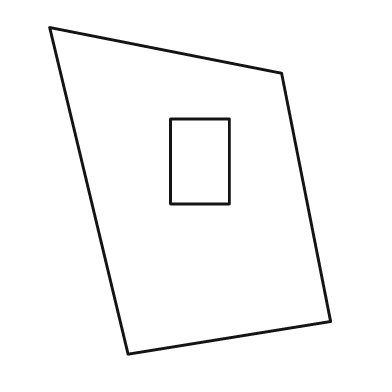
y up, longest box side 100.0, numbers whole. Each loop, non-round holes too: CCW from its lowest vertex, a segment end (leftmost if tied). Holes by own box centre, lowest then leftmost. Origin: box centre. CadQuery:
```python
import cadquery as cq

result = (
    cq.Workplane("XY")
    .moveTo(-19.0, -50.0)
    .lineTo(43.0, -40.0)
    .lineTo(28.0, 36.0)
    .lineTo(-43.0, 50.0)
    .close()
    .moveTo(-6.0, -4.0)
    .lineTo(12.0, -4.0)
    .lineTo(12.0, 22.0)
    .lineTo(-6.0, 22.0)
    .close()
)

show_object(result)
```